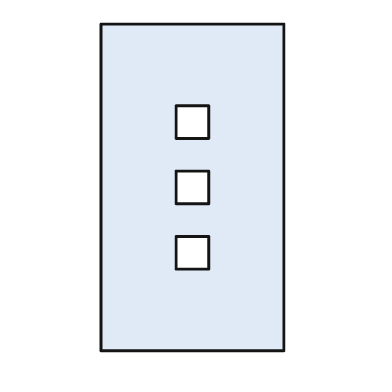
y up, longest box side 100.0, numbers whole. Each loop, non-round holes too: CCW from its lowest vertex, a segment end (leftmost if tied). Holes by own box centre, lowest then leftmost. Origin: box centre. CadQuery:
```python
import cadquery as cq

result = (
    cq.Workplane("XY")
    .moveTo(-28.0, -50.0)
    .lineTo(28.0, -50.0)
    .lineTo(28.0, 50.0)
    .lineTo(-28.0, 50.0)
    .close()
    .moveTo(-5.0, -25.0)
    .lineTo(5.0, -25.0)
    .lineTo(5.0, -15.0)
    .lineTo(-5.0, -15.0)
    .close()
    .moveTo(-5.0, -5.0)
    .lineTo(5.0, -5.0)
    .lineTo(5.0, 5.0)
    .lineTo(-5.0, 5.0)
    .close()
    .moveTo(-5.0, 15.0)
    .lineTo(5.0, 15.0)
    .lineTo(5.0, 25.0)
    .lineTo(-5.0, 25.0)
    .close()
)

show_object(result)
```